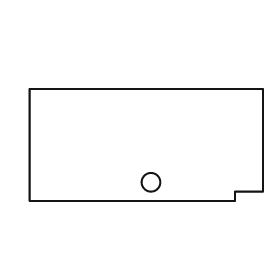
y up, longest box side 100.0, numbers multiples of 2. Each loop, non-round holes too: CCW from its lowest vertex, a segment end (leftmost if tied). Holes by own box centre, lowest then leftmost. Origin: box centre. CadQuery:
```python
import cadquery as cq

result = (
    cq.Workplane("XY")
    .moveTo(-50.0, -24.0)
    .lineTo(38.0, -24.0)
    .lineTo(38.0, -20.0)
    .lineTo(50.0, -20.0)
    .lineTo(50.0, 24.0)
    .lineTo(-50.0, 24.0)
    .close()
    .moveTo(2.0, -16.0)
    .circle(4.0)
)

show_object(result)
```